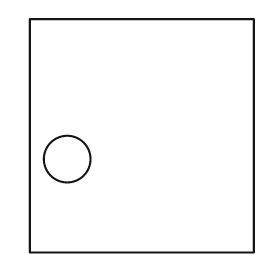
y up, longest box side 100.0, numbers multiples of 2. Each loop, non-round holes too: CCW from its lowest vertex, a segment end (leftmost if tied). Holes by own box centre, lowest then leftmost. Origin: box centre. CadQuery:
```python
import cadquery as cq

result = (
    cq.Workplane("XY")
    .moveTo(-48.0, -50.0)
    .lineTo(48.0, -50.0)
    .lineTo(48.0, 50.0)
    .lineTo(-48.0, 50.0)
    .close()
    .moveTo(-32.0, -10.0)
    .circle(10.0)
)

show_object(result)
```